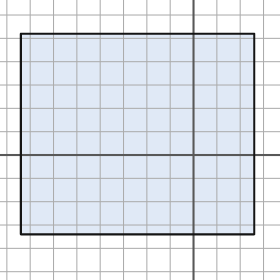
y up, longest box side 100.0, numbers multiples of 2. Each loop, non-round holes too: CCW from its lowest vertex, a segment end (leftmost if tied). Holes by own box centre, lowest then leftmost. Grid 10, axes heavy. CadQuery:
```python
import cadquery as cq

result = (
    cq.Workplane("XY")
    .moveTo(-74.0, -34.0)
    .lineTo(26.0, -34.0)
    .lineTo(26.0, 52.0)
    .lineTo(-74.0, 52.0)
    .close()
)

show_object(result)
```